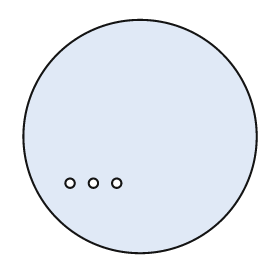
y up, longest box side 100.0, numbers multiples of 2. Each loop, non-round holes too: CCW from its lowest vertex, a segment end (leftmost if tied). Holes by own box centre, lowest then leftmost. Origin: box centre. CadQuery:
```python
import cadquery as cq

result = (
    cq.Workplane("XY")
    .moveTo(0.0, 0.0)
    .circle(50.0)
    .moveTo(-30.0, -20.0)
    .circle(2.0)
    .moveTo(-20.0, -20.0)
    .circle(2.0)
    .moveTo(-10.0, -20.0)
    .circle(2.0)
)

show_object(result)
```